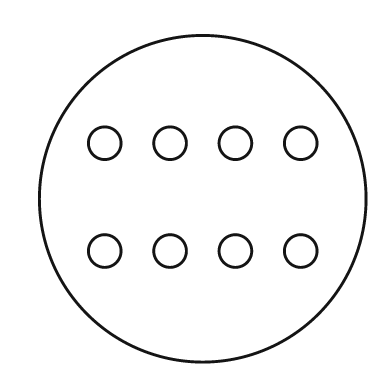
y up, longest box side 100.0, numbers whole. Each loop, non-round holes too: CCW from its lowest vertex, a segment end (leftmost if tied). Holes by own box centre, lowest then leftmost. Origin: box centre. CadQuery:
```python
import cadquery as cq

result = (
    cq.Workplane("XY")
    .moveTo(0.0, 0.0)
    .circle(50.0)
    .moveTo(-30.0, -16.0)
    .circle(5.0)
    .moveTo(-10.0, -16.0)
    .circle(5.0)
    .moveTo(10.0, -16.0)
    .circle(5.0)
    .moveTo(30.0, -16.0)
    .circle(5.0)
    .moveTo(-30.0, 17.0)
    .circle(5.0)
    .moveTo(-10.0, 17.0)
    .circle(5.0)
    .moveTo(10.0, 17.0)
    .circle(5.0)
    .moveTo(30.0, 17.0)
    .circle(5.0)
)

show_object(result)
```